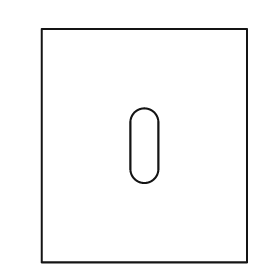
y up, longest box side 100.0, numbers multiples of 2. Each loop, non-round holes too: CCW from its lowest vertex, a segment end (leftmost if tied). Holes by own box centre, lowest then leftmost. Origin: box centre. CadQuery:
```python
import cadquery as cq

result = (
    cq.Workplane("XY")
    .moveTo(-44.0, -50.0)
    .lineTo(44.0, -50.0)
    .lineTo(44.0, 50.0)
    .lineTo(-44.0, 50.0)
    .close()
    .moveTo(-6.0, -10.0)
    .threePointArc((0.0, -16.0), (6.0, -10.0))
    .lineTo(6.0, 10.0)
    .threePointArc((0.0, 16.0), (-6.0, 10.0))
    .close()
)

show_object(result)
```